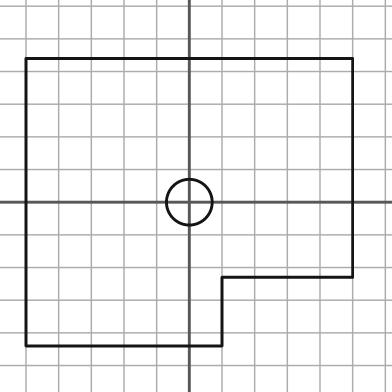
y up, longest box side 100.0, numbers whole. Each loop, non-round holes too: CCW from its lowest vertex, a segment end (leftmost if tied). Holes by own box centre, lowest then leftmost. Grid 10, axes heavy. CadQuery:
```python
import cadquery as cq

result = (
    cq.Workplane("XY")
    .moveTo(-50.0, -44.0)
    .lineTo(10.0, -44.0)
    .lineTo(10.0, -23.0)
    .lineTo(50.0, -23.0)
    .lineTo(50.0, 44.0)
    .lineTo(-50.0, 44.0)
    .close()
    .moveTo(0.0, 0.0)
    .circle(7.0)
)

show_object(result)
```